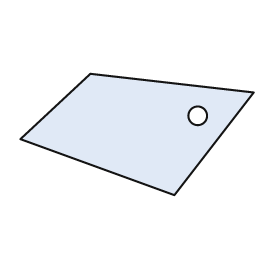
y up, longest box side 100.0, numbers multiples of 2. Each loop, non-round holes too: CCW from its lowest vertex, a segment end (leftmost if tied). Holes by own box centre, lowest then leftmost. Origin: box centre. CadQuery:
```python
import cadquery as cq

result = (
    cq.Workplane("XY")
    .moveTo(16.0, -26.0)
    .lineTo(50.0, 18.0)
    .lineTo(-20.0, 26.0)
    .lineTo(-50.0, -2.0)
    .close()
    .moveTo(26.0, 8.0)
    .circle(4.0)
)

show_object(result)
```